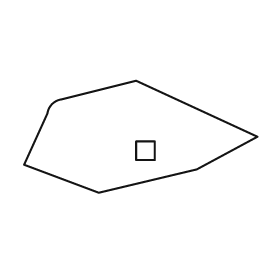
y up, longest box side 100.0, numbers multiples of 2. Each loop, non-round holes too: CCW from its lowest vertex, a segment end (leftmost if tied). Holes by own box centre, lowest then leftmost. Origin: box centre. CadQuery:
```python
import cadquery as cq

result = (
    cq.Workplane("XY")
    .moveTo(-18.0, -24.0)
    .lineTo(24.0, -14.0)
    .lineTo(50.0, 0.0)
    .lineTo(-2.0, 24.0)
    .lineTo(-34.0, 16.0)
    .threePointArc((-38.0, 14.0), (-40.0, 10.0))
    .lineTo(-50.0, -12.0)
    .close()
    .moveTo(-2.0, -10.0)
    .lineTo(6.0, -10.0)
    .lineTo(6.0, -2.0)
    .lineTo(-2.0, -2.0)
    .close()
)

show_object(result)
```